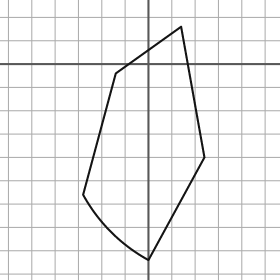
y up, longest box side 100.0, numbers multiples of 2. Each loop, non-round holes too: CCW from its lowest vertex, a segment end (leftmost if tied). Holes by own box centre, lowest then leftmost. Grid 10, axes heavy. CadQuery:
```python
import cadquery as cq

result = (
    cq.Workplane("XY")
    .moveTo(0.0, -84.0)
    .lineTo(24.0, -40.0)
    .lineTo(14.0, 16.0)
    .lineTo(-14.0, -4.0)
    .lineTo(-28.0, -56.0)
    .threePointArc((-16.0, -72.0), (0.0, -84.0))
    .close()
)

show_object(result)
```